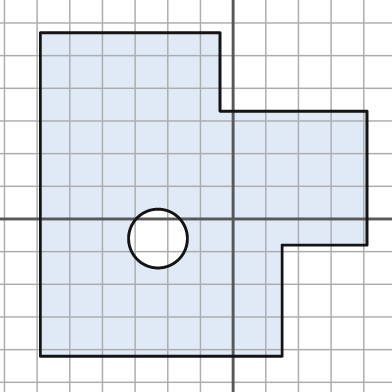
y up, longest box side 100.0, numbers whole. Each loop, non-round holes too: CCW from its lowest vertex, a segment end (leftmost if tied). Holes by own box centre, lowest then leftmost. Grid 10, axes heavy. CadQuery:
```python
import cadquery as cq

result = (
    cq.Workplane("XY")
    .moveTo(-59.0, -42.0)
    .lineTo(15.0, -42.0)
    .lineTo(15.0, -8.0)
    .lineTo(41.0, -8.0)
    .lineTo(41.0, 33.0)
    .lineTo(-4.0, 33.0)
    .lineTo(-4.0, 57.0)
    .lineTo(-59.0, 57.0)
    .close()
    .moveTo(-23.0, -6.0)
    .circle(9.0)
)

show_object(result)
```